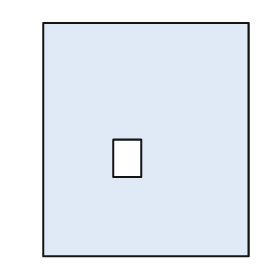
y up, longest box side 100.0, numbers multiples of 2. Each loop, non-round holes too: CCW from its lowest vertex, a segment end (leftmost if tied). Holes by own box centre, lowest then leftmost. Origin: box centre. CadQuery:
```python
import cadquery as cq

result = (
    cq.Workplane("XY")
    .moveTo(-44.0, -50.0)
    .lineTo(44.0, -50.0)
    .lineTo(44.0, 50.0)
    .lineTo(-44.0, 50.0)
    .close()
    .moveTo(-14.0, -16.0)
    .lineTo(-2.0, -16.0)
    .lineTo(-2.0, 0.0)
    .lineTo(-14.0, 0.0)
    .close()
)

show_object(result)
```